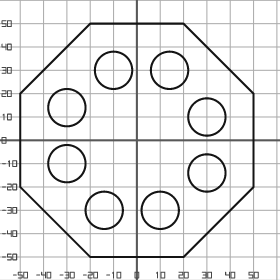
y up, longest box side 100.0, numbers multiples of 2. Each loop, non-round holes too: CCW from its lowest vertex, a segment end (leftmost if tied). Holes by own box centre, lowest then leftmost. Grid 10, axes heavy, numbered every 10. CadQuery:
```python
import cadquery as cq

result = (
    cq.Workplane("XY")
    .moveTo(-20.0, -50.0)
    .lineTo(20.0, -50.0)
    .lineTo(50.0, -20.0)
    .lineTo(50.0, 20.0)
    .lineTo(20.0, 50.0)
    .lineTo(-20.0, 50.0)
    .lineTo(-50.0, 20.0)
    .lineTo(-50.0, -20.0)
    .close()
    .moveTo(-14.0, -30.0)
    .circle(8.0)
    .moveTo(10.0, -30.0)
    .circle(8.0)
    .moveTo(30.0, -14.0)
    .circle(8.0)
    .moveTo(-30.0, -10.0)
    .circle(8.0)
    .moveTo(30.0, 10.0)
    .circle(8.0)
    .moveTo(-30.0, 14.0)
    .circle(8.0)
    .moveTo(-10.0, 30.0)
    .circle(8.0)
    .moveTo(14.0, 30.0)
    .circle(8.0)
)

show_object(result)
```